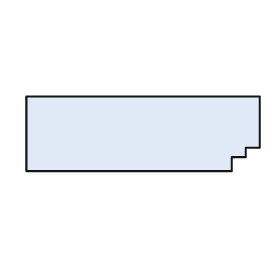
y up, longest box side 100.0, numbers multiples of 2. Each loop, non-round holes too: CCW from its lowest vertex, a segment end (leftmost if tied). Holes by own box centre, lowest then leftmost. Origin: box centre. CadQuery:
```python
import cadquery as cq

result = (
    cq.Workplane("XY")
    .moveTo(-50.0, -16.0)
    .lineTo(38.0, -16.0)
    .lineTo(38.0, -10.0)
    .lineTo(44.0, -10.0)
    .lineTo(44.0, -6.0)
    .lineTo(50.0, -6.0)
    .lineTo(50.0, 16.0)
    .lineTo(-50.0, 16.0)
    .close()
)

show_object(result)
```